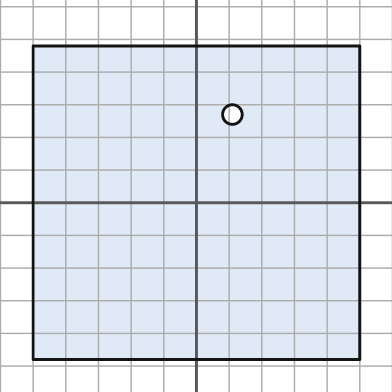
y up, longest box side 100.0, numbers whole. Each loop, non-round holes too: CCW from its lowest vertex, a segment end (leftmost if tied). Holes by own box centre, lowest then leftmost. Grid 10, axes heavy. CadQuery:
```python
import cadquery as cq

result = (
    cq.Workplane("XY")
    .moveTo(-50.0, -48.0)
    .lineTo(50.0, -48.0)
    .lineTo(50.0, 48.0)
    .lineTo(-50.0, 48.0)
    .close()
    .moveTo(11.0, 27.0)
    .circle(3.0)
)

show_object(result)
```